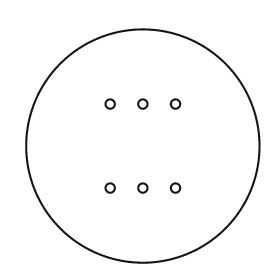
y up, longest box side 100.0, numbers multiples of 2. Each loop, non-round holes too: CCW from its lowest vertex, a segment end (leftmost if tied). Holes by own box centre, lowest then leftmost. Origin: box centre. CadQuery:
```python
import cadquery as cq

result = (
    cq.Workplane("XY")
    .moveTo(0.0, 0.0)
    .circle(50.0)
    .moveTo(-14.0, -18.0)
    .circle(2.0)
    .moveTo(0.0, -18.0)
    .circle(2.0)
    .moveTo(14.0, -18.0)
    .circle(2.0)
    .moveTo(-14.0, 18.0)
    .circle(2.0)
    .moveTo(0.0, 18.0)
    .circle(2.0)
    .moveTo(14.0, 18.0)
    .circle(2.0)
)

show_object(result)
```